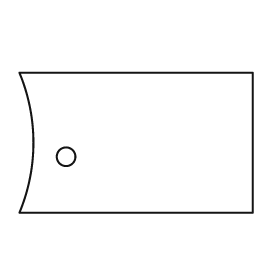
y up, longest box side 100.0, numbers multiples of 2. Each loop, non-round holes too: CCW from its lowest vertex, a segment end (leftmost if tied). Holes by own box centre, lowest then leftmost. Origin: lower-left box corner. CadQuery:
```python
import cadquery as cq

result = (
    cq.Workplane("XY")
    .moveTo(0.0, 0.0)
    .lineTo(100.0, 0.0)
    .lineTo(100.0, 60.0)
    .lineTo(0.0, 60.0)
    .threePointArc((6.0, 30.0), (0.0, 0.0))
    .close()
    .moveTo(20.0, 24.0)
    .circle(4.0)
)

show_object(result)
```